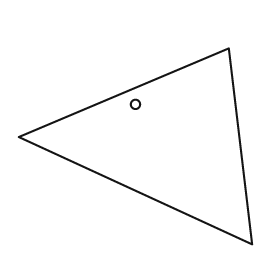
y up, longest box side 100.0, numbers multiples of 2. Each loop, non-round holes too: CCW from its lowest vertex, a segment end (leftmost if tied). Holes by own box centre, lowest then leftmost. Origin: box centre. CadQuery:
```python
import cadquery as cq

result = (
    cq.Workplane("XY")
    .moveTo(50.0, -42.0)
    .lineTo(40.0, 42.0)
    .lineTo(-50.0, 4.0)
    .close()
    .moveTo(0.0, 18.0)
    .circle(2.0)
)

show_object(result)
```